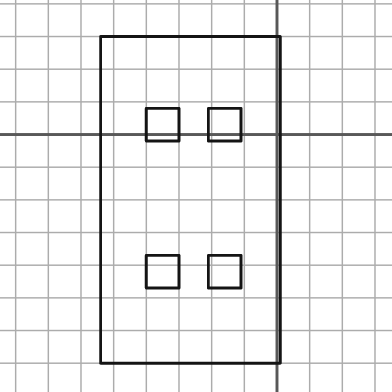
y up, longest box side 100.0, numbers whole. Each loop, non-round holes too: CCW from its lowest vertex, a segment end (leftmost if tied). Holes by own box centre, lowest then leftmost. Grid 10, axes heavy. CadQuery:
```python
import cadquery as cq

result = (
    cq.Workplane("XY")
    .moveTo(-54.0, -70.0)
    .lineTo(1.0, -70.0)
    .lineTo(1.0, 30.0)
    .lineTo(-54.0, 30.0)
    .close()
    .moveTo(-40.0, -47.0)
    .lineTo(-30.0, -47.0)
    .lineTo(-30.0, -37.0)
    .lineTo(-40.0, -37.0)
    .close()
    .moveTo(-21.0, -47.0)
    .lineTo(-11.0, -47.0)
    .lineTo(-11.0, -37.0)
    .lineTo(-21.0, -37.0)
    .close()
    .moveTo(-40.0, -2.0)
    .lineTo(-30.0, -2.0)
    .lineTo(-30.0, 8.0)
    .lineTo(-40.0, 8.0)
    .close()
    .moveTo(-21.0, -2.0)
    .lineTo(-11.0, -2.0)
    .lineTo(-11.0, 8.0)
    .lineTo(-21.0, 8.0)
    .close()
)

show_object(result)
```